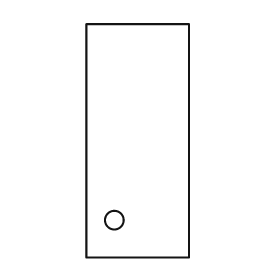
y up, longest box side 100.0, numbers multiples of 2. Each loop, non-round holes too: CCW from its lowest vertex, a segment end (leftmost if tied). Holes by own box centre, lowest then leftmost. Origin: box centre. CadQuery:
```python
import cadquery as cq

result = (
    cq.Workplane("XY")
    .moveTo(-22.0, -50.0)
    .lineTo(22.0, -50.0)
    .lineTo(22.0, 50.0)
    .lineTo(-22.0, 50.0)
    .close()
    .moveTo(-10.0, -34.0)
    .circle(4.0)
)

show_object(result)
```